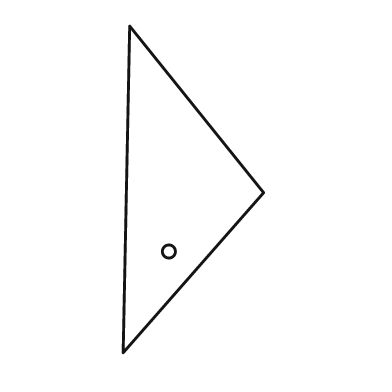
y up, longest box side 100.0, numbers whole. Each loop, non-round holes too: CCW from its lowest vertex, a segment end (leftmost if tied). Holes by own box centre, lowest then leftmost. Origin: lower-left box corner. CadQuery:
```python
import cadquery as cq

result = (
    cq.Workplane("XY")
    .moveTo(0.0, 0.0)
    .lineTo(43.0, 49.0)
    .lineTo(2.0, 100.0)
    .close()
    .moveTo(14.0, 31.0)
    .circle(2.0)
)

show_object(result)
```